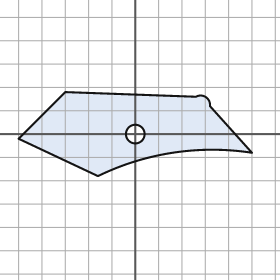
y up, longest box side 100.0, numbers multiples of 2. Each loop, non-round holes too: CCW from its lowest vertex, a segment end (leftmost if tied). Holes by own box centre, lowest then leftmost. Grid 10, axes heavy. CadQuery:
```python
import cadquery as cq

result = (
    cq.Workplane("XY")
    .moveTo(-16.0, -18.0)
    .threePointArc((16.0, -8.0), (50.0, -8.0))
    .lineTo(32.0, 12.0)
    .threePointArc((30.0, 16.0), (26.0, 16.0))
    .lineTo(-30.0, 18.0)
    .lineTo(-50.0, -2.0)
    .close()
    .moveTo(0.0, 0.0)
    .circle(4.0)
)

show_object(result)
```